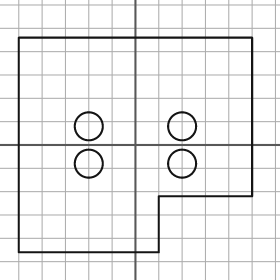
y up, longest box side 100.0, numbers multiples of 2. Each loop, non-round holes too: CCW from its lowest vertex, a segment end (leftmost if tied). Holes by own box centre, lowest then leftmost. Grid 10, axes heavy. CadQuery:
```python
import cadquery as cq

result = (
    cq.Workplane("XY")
    .moveTo(-50.0, -46.0)
    .lineTo(10.0, -46.0)
    .lineTo(10.0, -22.0)
    .lineTo(50.0, -22.0)
    .lineTo(50.0, 46.0)
    .lineTo(-50.0, 46.0)
    .close()
    .moveTo(-20.0, -8.0)
    .circle(6.0)
    .moveTo(20.0, -8.0)
    .circle(6.0)
    .moveTo(-20.0, 8.0)
    .circle(6.0)
    .moveTo(20.0, 8.0)
    .circle(6.0)
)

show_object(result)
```